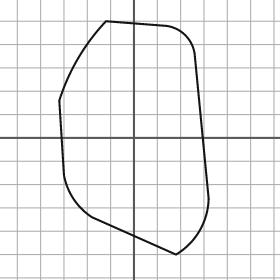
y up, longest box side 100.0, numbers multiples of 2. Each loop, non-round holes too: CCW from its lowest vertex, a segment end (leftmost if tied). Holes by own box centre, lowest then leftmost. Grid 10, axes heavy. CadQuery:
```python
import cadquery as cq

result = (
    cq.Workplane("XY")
    .moveTo(18.0, -50.0)
    .threePointArc((28.0, -40.0), (32.0, -26.0))
    .lineTo(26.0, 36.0)
    .threePointArc((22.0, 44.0), (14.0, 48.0))
    .lineTo(-12.0, 50.0)
    .threePointArc((-24.0, 34.0), (-32.0, 16.0))
    .lineTo(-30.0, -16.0)
    .threePointArc((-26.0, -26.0), (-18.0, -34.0))
    .close()
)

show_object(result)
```